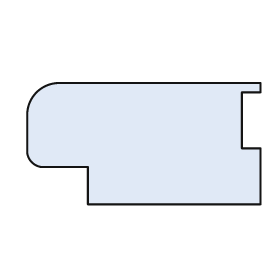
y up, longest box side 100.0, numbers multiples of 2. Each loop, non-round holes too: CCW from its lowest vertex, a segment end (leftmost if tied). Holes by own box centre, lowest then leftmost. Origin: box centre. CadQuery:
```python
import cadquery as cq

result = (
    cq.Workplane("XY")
    .moveTo(-24.0, -26.0)
    .lineTo(50.0, -26.0)
    .lineTo(50.0, -2.0)
    .lineTo(42.0, -2.0)
    .lineTo(42.0, 22.0)
    .lineTo(50.0, 22.0)
    .lineTo(50.0, 26.0)
    .lineTo(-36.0, 26.0)
    .threePointArc((-46.0, 22.0), (-50.0, 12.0))
    .lineTo(-50.0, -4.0)
    .threePointArc((-48.0, -8.0), (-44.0, -10.0))
    .lineTo(-24.0, -10.0)
    .close()
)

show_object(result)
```